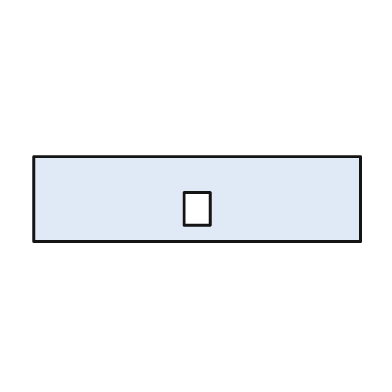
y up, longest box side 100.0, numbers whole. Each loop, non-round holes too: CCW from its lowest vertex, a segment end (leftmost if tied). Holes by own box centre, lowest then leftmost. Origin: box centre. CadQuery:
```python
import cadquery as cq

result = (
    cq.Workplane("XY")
    .moveTo(-50.0, -13.0)
    .lineTo(50.0, -13.0)
    .lineTo(50.0, 13.0)
    .lineTo(-50.0, 13.0)
    .close()
    .moveTo(-4.0, -8.0)
    .lineTo(4.0, -8.0)
    .lineTo(4.0, 2.0)
    .lineTo(-4.0, 2.0)
    .close()
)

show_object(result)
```